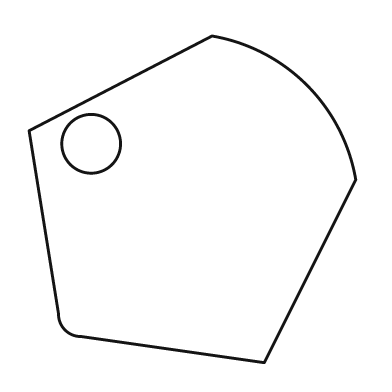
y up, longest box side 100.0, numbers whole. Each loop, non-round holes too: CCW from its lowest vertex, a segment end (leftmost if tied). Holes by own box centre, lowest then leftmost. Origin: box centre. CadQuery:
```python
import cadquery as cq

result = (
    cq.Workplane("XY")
    .moveTo(22.0, -50.0)
    .lineTo(50.0, 6.0)
    .threePointArc((35.0, 35.0), (6.0, 50.0))
    .lineTo(-50.0, 21.0)
    .lineTo(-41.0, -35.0)
    .threePointArc((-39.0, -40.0), (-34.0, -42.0))
    .close()
    .moveTo(-31.0, 17.0)
    .circle(9.0)
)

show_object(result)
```